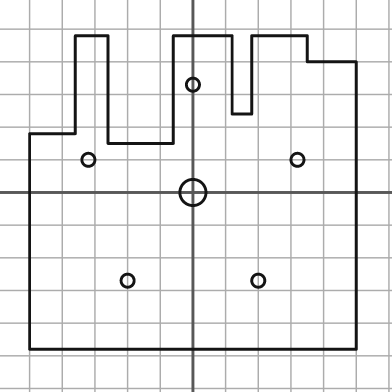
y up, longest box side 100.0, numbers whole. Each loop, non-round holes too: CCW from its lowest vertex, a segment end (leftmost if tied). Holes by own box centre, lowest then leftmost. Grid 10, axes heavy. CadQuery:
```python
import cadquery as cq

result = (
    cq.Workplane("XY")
    .moveTo(-50.0, -48.0)
    .lineTo(50.0, -48.0)
    .lineTo(50.0, 40.0)
    .lineTo(35.0, 40.0)
    .lineTo(35.0, 48.0)
    .lineTo(18.0, 48.0)
    .lineTo(18.0, 24.0)
    .lineTo(12.0, 24.0)
    .lineTo(12.0, 48.0)
    .lineTo(-6.0, 48.0)
    .lineTo(-6.0, 15.0)
    .lineTo(-26.0, 15.0)
    .lineTo(-26.0, 48.0)
    .lineTo(-36.0, 48.0)
    .lineTo(-36.0, 18.0)
    .lineTo(-50.0, 18.0)
    .close()
    .moveTo(-20.0, -27.0)
    .circle(2.0)
    .moveTo(20.0, -27.0)
    .circle(2.0)
    .moveTo(0.0, 0.0)
    .circle(4.0)
    .moveTo(-32.0, 10.0)
    .circle(2.0)
    .moveTo(32.0, 10.0)
    .circle(2.0)
    .moveTo(0.0, 33.0)
    .circle(2.0)
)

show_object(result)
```